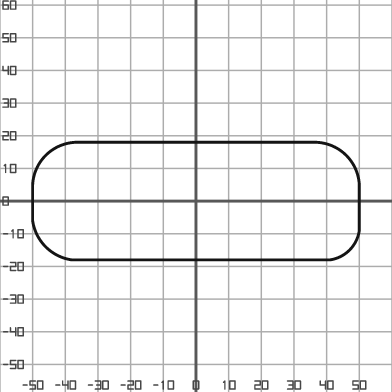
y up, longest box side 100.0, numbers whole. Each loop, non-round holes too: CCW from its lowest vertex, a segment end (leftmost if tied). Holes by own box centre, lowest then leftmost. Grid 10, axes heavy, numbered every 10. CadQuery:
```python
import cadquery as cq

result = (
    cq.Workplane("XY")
    .moveTo(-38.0, -18.0)
    .lineTo(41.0, -18.0)
    .threePointArc((47.0, -15.0), (50.0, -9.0))
    .lineTo(50.0, 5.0)
    .threePointArc((46.0, 14.0), (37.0, 18.0))
    .lineTo(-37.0, 18.0)
    .threePointArc((-46.0, 14.0), (-50.0, 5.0))
    .lineTo(-50.0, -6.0)
    .threePointArc((-46.0, -14.0), (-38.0, -18.0))
    .close()
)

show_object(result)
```